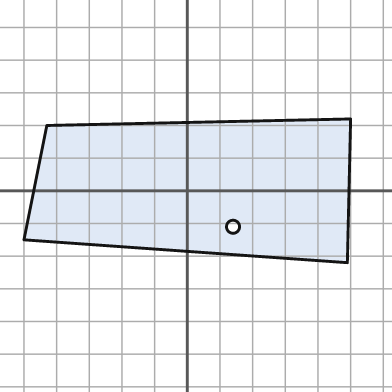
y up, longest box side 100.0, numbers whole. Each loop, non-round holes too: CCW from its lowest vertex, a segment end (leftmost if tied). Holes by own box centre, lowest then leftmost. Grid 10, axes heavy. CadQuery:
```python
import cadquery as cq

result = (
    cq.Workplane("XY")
    .moveTo(49.0, -22.0)
    .lineTo(50.0, 22.0)
    .lineTo(-43.0, 20.0)
    .lineTo(-50.0, -15.0)
    .close()
    .moveTo(14.0, -11.0)
    .circle(2.0)
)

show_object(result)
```